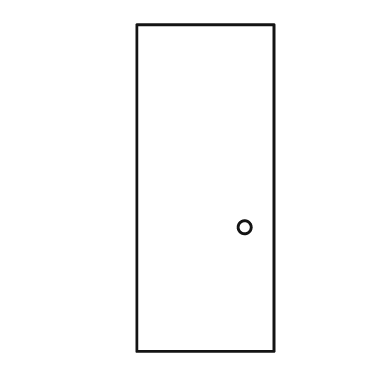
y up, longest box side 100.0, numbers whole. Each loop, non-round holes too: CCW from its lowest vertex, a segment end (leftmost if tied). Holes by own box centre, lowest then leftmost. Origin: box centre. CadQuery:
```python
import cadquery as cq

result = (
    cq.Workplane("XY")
    .moveTo(-21.0, -50.0)
    .lineTo(21.0, -50.0)
    .lineTo(21.0, 50.0)
    .lineTo(-21.0, 50.0)
    .close()
    .moveTo(12.0, -12.0)
    .circle(2.0)
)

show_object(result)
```